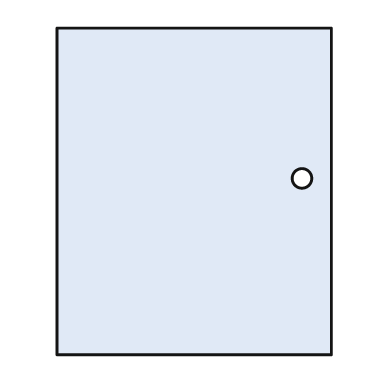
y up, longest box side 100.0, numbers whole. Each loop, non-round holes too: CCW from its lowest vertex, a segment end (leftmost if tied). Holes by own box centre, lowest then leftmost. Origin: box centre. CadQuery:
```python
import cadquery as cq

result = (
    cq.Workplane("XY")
    .moveTo(-42.0, -50.0)
    .lineTo(42.0, -50.0)
    .lineTo(42.0, 50.0)
    .lineTo(-42.0, 50.0)
    .close()
    .moveTo(33.0, 4.0)
    .circle(3.0)
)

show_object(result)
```